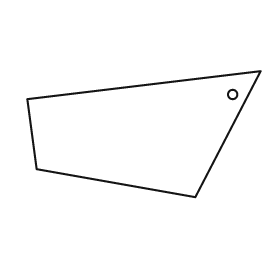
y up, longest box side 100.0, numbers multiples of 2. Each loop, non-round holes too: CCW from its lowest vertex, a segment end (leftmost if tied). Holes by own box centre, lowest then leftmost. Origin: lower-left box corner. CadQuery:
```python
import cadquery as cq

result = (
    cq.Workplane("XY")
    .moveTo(72.0, 0.0)
    .lineTo(100.0, 54.0)
    .lineTo(0.0, 42.0)
    .lineTo(4.0, 12.0)
    .close()
    .moveTo(88.0, 44.0)
    .circle(2.0)
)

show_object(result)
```